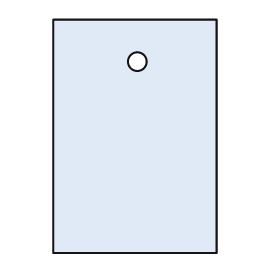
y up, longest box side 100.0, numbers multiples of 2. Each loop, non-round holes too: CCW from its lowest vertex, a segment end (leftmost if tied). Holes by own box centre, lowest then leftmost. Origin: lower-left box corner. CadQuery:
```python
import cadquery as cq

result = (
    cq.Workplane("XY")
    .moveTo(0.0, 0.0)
    .lineTo(70.0, 0.0)
    .lineTo(70.0, 100.0)
    .lineTo(0.0, 100.0)
    .close()
    .moveTo(36.0, 82.0)
    .circle(4.0)
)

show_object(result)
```